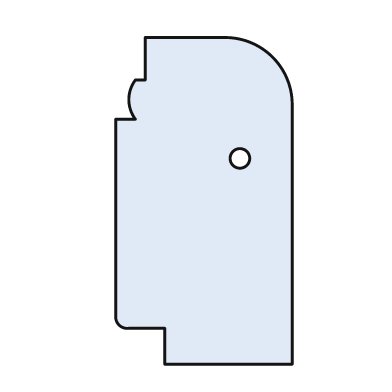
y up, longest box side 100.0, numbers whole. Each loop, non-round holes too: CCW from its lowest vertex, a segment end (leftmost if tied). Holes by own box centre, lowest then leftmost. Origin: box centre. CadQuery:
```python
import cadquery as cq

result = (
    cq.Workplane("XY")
    .moveTo(-12.0, -50.0)
    .lineTo(27.0, -50.0)
    .lineTo(27.0, 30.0)
    .threePointArc((21.0, 44.0), (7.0, 50.0))
    .lineTo(-18.0, 50.0)
    .lineTo(-18.0, 37.0)
    .lineTo(-21.0, 37.0)
    .threePointArc((-23.0, 31.0), (-21.0, 25.0))
    .lineTo(-27.0, 25.0)
    .lineTo(-27.0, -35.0)
    .threePointArc((-26.0, -38.0), (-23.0, -39.0))
    .lineTo(-12.0, -39.0)
    .close()
    .moveTo(11.0, 13.0)
    .circle(3.0)
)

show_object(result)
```